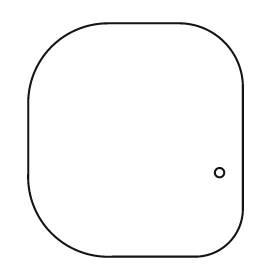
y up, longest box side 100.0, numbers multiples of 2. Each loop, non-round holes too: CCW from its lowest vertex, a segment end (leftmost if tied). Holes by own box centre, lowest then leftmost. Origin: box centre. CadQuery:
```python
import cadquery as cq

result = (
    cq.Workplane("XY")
    .moveTo(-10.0, -50.0)
    .lineTo(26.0, -50.0)
    .threePointArc((40.0, -44.0), (46.0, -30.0))
    .lineTo(46.0, 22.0)
    .threePointArc((38.0, 42.0), (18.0, 50.0))
    .lineTo(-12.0, 50.0)
    .threePointArc((-36.0, 40.0), (-46.0, 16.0))
    .lineTo(-46.0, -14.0)
    .threePointArc((-36.0, -40.0), (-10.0, -50.0))
    .close()
    .moveTo(36.0, -14.0)
    .circle(2.0)
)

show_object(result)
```